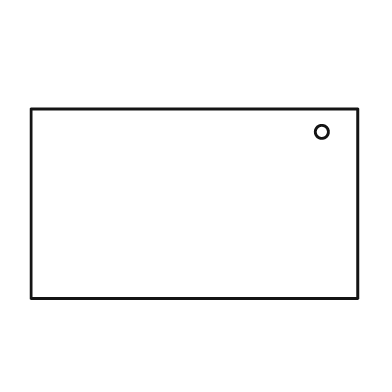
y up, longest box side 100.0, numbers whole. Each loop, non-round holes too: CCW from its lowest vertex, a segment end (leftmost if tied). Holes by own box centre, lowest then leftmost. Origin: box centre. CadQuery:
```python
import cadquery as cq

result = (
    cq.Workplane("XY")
    .moveTo(-50.0, -29.0)
    .lineTo(50.0, -29.0)
    .lineTo(50.0, 29.0)
    .lineTo(-50.0, 29.0)
    .close()
    .moveTo(39.0, 22.0)
    .circle(2.0)
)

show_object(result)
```